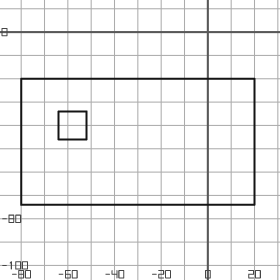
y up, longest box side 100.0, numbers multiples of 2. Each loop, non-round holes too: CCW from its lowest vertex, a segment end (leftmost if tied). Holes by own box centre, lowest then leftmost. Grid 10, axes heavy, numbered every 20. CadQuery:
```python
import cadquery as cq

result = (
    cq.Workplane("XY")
    .moveTo(-80.0, -74.0)
    .lineTo(20.0, -74.0)
    .lineTo(20.0, -20.0)
    .lineTo(-80.0, -20.0)
    .close()
    .moveTo(-64.0, -46.0)
    .lineTo(-52.0, -46.0)
    .lineTo(-52.0, -34.0)
    .lineTo(-64.0, -34.0)
    .close()
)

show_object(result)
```